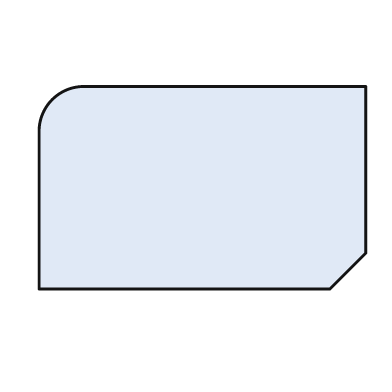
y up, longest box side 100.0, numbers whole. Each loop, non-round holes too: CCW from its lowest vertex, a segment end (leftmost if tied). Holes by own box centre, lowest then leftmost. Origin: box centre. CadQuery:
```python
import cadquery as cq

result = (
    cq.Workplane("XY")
    .moveTo(-50.0, -31.0)
    .lineTo(39.0, -31.0)
    .lineTo(50.0, -20.0)
    .lineTo(50.0, 31.0)
    .lineTo(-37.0, 31.0)
    .threePointArc((-46.0, 27.0), (-50.0, 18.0))
    .close()
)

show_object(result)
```